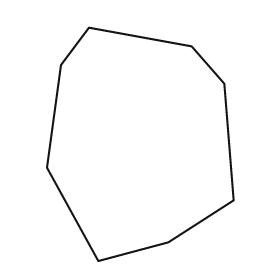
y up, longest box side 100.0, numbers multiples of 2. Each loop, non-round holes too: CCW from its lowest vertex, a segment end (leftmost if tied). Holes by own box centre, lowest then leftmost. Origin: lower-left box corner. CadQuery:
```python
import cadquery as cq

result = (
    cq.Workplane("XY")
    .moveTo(22.0, 0.0)
    .lineTo(52.0, 8.0)
    .lineTo(80.0, 26.0)
    .lineTo(76.0, 76.0)
    .lineTo(62.0, 92.0)
    .lineTo(18.0, 100.0)
    .lineTo(6.0, 84.0)
    .lineTo(0.0, 40.0)
    .close()
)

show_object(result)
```